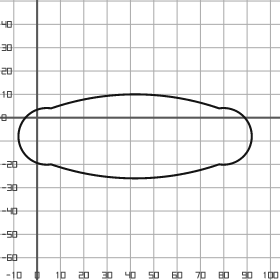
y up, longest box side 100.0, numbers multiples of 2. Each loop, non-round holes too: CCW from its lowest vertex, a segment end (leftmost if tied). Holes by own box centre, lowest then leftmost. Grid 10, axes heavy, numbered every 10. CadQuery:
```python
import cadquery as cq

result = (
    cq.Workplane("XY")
    .moveTo(6.0, -20.0)
    .threePointArc((42.0, -26.0), (78.0, -20.0))
    .threePointArc((92.0, -8.0), (78.0, 4.0))
    .threePointArc((42.0, 10.0), (6.0, 4.0))
    .threePointArc((-8.0, -8.0), (6.0, -20.0))
    .close()
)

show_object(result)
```